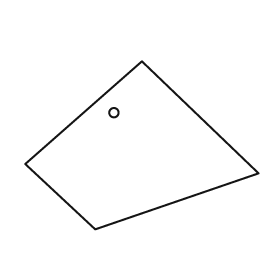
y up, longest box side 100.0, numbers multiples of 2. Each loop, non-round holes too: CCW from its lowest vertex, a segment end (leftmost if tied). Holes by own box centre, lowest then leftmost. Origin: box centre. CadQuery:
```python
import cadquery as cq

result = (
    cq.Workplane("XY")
    .moveTo(-20.0, -36.0)
    .lineTo(50.0, -12.0)
    .lineTo(0.0, 36.0)
    .lineTo(-50.0, -8.0)
    .close()
    .moveTo(-12.0, 14.0)
    .circle(2.0)
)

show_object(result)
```